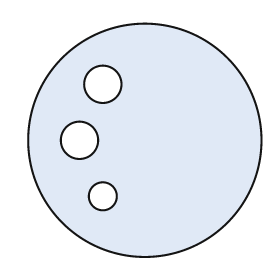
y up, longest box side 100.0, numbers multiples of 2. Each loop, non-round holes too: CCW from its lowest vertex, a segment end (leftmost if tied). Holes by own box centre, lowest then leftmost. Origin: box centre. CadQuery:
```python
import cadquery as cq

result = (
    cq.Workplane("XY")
    .moveTo(0.0, 0.0)
    .circle(50.0)
    .moveTo(-18.0, -24.0)
    .circle(6.0)
    .moveTo(-28.0, 0.0)
    .circle(8.0)
    .moveTo(-18.0, 24.0)
    .circle(8.0)
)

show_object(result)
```